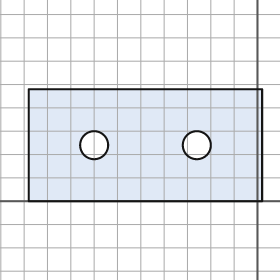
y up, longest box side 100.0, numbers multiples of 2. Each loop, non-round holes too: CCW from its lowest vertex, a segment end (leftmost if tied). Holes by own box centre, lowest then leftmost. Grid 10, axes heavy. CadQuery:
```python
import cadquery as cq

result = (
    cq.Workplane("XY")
    .moveTo(-98.0, 0.0)
    .lineTo(2.0, 0.0)
    .lineTo(2.0, 48.0)
    .lineTo(-98.0, 48.0)
    .close()
    .moveTo(-70.0, 24.0)
    .circle(6.0)
    .moveTo(-26.0, 24.0)
    .circle(6.0)
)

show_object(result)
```